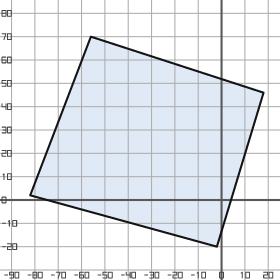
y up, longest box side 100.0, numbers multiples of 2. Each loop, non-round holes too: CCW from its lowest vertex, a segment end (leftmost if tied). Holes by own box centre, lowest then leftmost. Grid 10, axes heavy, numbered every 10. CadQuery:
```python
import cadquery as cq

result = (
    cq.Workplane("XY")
    .moveTo(-2.0, -20.0)
    .lineTo(18.0, 46.0)
    .lineTo(-56.0, 70.0)
    .lineTo(-82.0, 2.0)
    .close()
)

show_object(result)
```